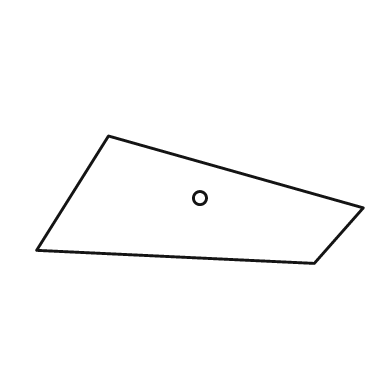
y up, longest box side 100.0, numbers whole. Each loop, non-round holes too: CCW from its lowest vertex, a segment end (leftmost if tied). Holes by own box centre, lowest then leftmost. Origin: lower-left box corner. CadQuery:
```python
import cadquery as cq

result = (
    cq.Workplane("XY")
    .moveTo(85.0, 0.0)
    .lineTo(100.0, 17.0)
    .lineTo(22.0, 39.0)
    .lineTo(0.0, 4.0)
    .close()
    .moveTo(50.0, 20.0)
    .circle(2.0)
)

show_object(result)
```